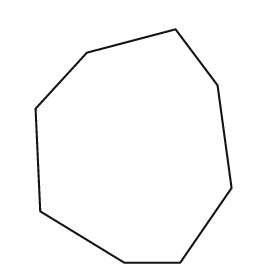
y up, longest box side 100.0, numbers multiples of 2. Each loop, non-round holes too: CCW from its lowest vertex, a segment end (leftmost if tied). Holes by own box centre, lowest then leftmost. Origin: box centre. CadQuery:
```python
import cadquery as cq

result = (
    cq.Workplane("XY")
    .moveTo(-4.0, -50.0)
    .lineTo(20.0, -50.0)
    .lineTo(42.0, -18.0)
    .lineTo(36.0, 26.0)
    .lineTo(18.0, 50.0)
    .lineTo(-20.0, 40.0)
    .lineTo(-42.0, 16.0)
    .lineTo(-40.0, -28.0)
    .close()
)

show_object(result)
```